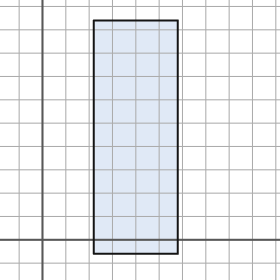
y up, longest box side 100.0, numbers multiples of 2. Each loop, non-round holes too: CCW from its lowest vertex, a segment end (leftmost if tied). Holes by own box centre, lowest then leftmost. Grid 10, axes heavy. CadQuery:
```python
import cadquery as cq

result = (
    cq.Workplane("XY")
    .moveTo(22.0, -6.0)
    .lineTo(58.0, -6.0)
    .lineTo(58.0, 94.0)
    .lineTo(22.0, 94.0)
    .close()
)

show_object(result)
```